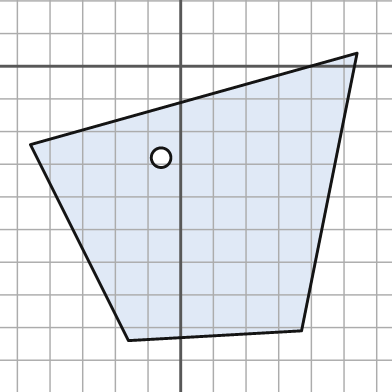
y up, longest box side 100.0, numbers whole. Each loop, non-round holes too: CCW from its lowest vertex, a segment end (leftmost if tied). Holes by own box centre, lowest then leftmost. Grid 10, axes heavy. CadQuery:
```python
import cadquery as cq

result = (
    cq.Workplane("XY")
    .moveTo(-16.0, -84.0)
    .lineTo(37.0, -81.0)
    .lineTo(54.0, 4.0)
    .lineTo(-46.0, -24.0)
    .close()
    .moveTo(-6.0, -28.0)
    .circle(3.0)
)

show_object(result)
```